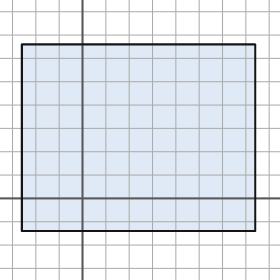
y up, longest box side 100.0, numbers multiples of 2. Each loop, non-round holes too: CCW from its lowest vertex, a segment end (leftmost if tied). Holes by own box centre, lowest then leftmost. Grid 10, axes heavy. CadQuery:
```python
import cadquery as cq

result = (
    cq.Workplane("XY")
    .moveTo(-26.0, -14.0)
    .lineTo(74.0, -14.0)
    .lineTo(74.0, 66.0)
    .lineTo(-26.0, 66.0)
    .close()
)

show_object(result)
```